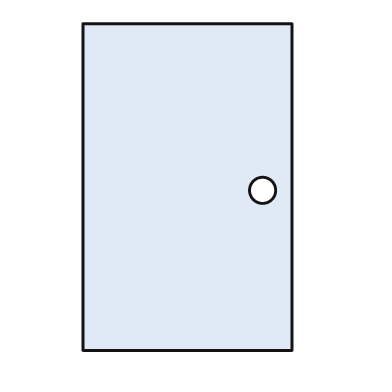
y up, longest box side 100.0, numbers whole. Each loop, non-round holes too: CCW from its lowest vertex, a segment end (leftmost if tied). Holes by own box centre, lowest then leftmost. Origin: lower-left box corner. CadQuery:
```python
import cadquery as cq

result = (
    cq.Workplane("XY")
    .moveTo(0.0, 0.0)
    .lineTo(64.0, 0.0)
    .lineTo(64.0, 100.0)
    .lineTo(0.0, 100.0)
    .close()
    .moveTo(55.0, 49.0)
    .circle(4.0)
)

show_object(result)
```